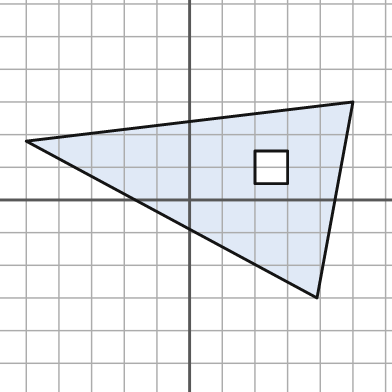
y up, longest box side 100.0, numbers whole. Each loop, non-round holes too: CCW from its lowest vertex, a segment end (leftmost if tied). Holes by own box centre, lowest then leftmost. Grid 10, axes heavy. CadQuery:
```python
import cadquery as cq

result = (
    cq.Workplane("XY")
    .moveTo(39.0, -30.0)
    .lineTo(50.0, 30.0)
    .lineTo(-50.0, 18.0)
    .close()
    .moveTo(20.0, 5.0)
    .lineTo(30.0, 5.0)
    .lineTo(30.0, 15.0)
    .lineTo(20.0, 15.0)
    .close()
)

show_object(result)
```